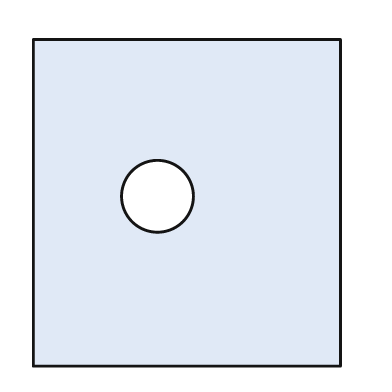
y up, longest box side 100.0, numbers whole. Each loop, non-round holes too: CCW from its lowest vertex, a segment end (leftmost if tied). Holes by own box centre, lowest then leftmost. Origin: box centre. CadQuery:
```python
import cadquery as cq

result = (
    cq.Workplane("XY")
    .moveTo(-47.0, -50.0)
    .lineTo(47.0, -50.0)
    .lineTo(47.0, 50.0)
    .lineTo(-47.0, 50.0)
    .close()
    .moveTo(-9.0, 2.0)
    .circle(11.0)
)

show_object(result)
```